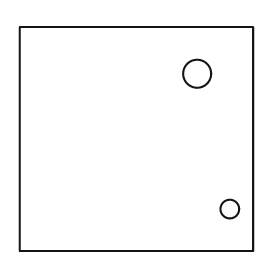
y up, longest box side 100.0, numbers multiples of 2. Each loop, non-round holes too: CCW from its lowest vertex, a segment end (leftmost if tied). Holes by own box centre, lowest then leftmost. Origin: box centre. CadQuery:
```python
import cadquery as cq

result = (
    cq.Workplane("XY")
    .moveTo(-50.0, -48.0)
    .lineTo(50.0, -48.0)
    .lineTo(50.0, 48.0)
    .lineTo(-50.0, 48.0)
    .close()
    .moveTo(40.0, -30.0)
    .circle(4.0)
    .moveTo(26.0, 28.0)
    .circle(6.0)
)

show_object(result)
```